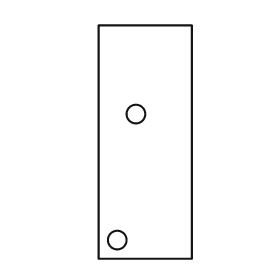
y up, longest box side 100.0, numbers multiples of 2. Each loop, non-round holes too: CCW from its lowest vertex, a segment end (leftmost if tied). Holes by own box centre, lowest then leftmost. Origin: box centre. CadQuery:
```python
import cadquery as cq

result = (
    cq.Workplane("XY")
    .moveTo(-20.0, -50.0)
    .lineTo(20.0, -50.0)
    .lineTo(20.0, 50.0)
    .lineTo(-20.0, 50.0)
    .close()
    .moveTo(-12.0, -42.0)
    .circle(4.0)
    .moveTo(-4.0, 12.0)
    .circle(4.0)
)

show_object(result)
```